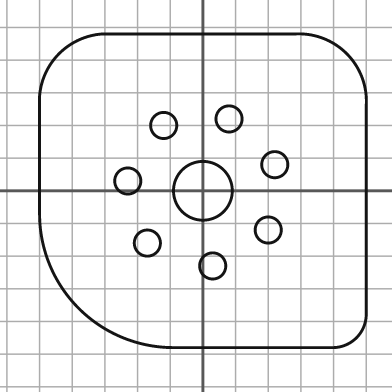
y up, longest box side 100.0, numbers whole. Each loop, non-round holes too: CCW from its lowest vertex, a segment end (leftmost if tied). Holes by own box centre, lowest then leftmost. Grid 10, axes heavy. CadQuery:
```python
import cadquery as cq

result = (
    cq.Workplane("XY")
    .moveTo(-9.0, -48.0)
    .lineTo(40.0, -48.0)
    .threePointArc((47.0, -45.0), (50.0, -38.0))
    .lineTo(50.0, 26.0)
    .threePointArc((44.0, 42.0), (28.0, 48.0))
    .lineTo(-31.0, 48.0)
    .threePointArc((-44.0, 42.0), (-50.0, 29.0))
    .lineTo(-50.0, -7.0)
    .threePointArc((-38.0, -36.0), (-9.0, -48.0))
    .close()
    .moveTo(3.0, -23.0)
    .circle(4.0)
    .moveTo(-17.0, -16.0)
    .circle(4.0)
    .moveTo(20.0, -12.0)
    .circle(4.0)
    .moveTo(0.0, 0.0)
    .circle(9.0)
    .moveTo(-23.0, 3.0)
    .circle(4.0)
    .moveTo(22.0, 8.0)
    .circle(4.0)
    .moveTo(-12.0, 20.0)
    .circle(4.0)
    .moveTo(8.0, 22.0)
    .circle(4.0)
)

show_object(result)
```